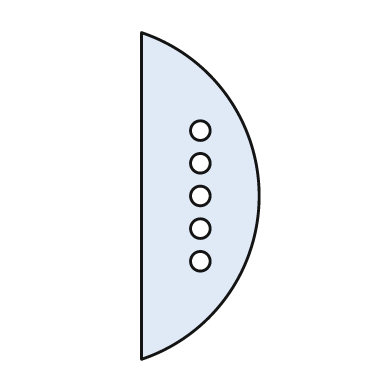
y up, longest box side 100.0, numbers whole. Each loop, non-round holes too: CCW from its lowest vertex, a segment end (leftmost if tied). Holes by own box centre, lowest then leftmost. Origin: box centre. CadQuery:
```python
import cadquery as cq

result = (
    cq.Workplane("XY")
    .moveTo(-18.0, -50.0)
    .threePointArc((18.0, 0.0), (-18.0, 50.0))
    .close()
    .moveTo(0.0, -20.0)
    .circle(3.0)
    .moveTo(0.0, -10.0)
    .circle(3.0)
    .moveTo(0.0, 0.0)
    .circle(3.0)
    .moveTo(0.0, 10.0)
    .circle(3.0)
    .moveTo(0.0, 20.0)
    .circle(3.0)
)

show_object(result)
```